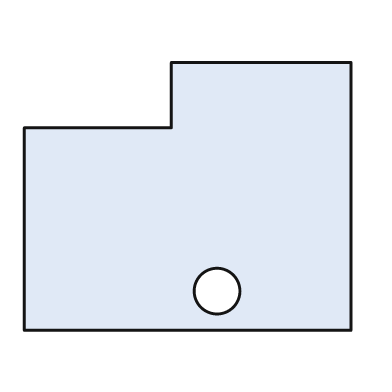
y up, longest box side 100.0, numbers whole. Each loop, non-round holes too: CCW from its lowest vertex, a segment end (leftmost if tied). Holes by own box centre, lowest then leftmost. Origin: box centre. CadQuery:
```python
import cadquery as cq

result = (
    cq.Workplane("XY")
    .moveTo(-50.0, -41.0)
    .lineTo(50.0, -41.0)
    .lineTo(50.0, 41.0)
    .lineTo(-5.0, 41.0)
    .lineTo(-5.0, 21.0)
    .lineTo(-50.0, 21.0)
    .close()
    .moveTo(9.0, -29.0)
    .circle(7.0)
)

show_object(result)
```